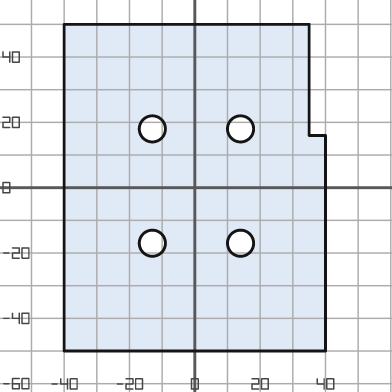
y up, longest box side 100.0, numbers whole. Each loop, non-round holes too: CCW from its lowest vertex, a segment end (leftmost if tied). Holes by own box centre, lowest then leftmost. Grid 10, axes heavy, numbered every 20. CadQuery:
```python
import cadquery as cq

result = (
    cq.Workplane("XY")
    .moveTo(-40.0, -50.0)
    .lineTo(40.0, -50.0)
    .lineTo(40.0, 16.0)
    .lineTo(35.0, 16.0)
    .lineTo(35.0, 50.0)
    .lineTo(-40.0, 50.0)
    .close()
    .moveTo(-13.0, -17.0)
    .circle(4.0)
    .moveTo(14.0, -17.0)
    .circle(4.0)
    .moveTo(-13.0, 18.0)
    .circle(4.0)
    .moveTo(14.0, 18.0)
    .circle(4.0)
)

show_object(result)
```